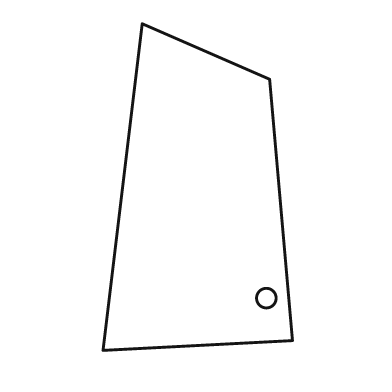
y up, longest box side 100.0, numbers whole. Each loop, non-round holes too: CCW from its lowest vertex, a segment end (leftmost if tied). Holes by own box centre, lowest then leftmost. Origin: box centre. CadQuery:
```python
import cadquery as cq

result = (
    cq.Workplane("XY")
    .moveTo(-29.0, -50.0)
    .lineTo(29.0, -47.0)
    .lineTo(22.0, 33.0)
    .lineTo(-17.0, 50.0)
    .close()
    .moveTo(21.0, -34.0)
    .circle(3.0)
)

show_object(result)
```